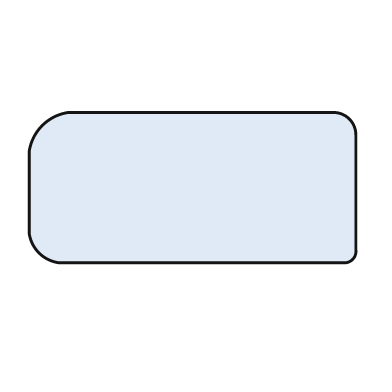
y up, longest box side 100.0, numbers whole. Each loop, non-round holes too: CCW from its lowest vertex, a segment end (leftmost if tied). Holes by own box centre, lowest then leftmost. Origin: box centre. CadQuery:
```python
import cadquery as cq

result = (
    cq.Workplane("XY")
    .moveTo(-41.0, -23.0)
    .lineTo(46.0, -23.0)
    .threePointArc((49.0, -22.0), (50.0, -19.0))
    .lineTo(50.0, 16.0)
    .threePointArc((48.0, 21.0), (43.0, 23.0))
    .lineTo(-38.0, 23.0)
    .threePointArc((-46.0, 19.0), (-50.0, 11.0))
    .lineTo(-50.0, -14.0)
    .threePointArc((-47.0, -20.0), (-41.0, -23.0))
    .close()
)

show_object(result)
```